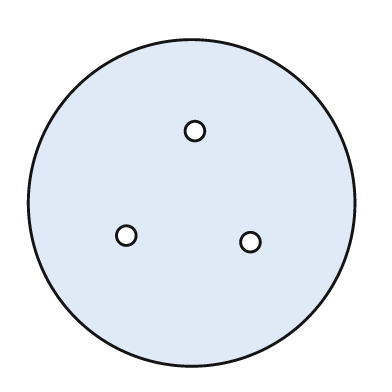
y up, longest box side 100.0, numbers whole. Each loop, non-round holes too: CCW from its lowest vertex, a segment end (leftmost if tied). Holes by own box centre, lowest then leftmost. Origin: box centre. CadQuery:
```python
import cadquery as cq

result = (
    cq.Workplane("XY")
    .moveTo(0.0, 0.0)
    .circle(50.0)
    .moveTo(18.0, -12.0)
    .circle(3.0)
    .moveTo(-20.0, -10.0)
    .circle(3.0)
    .moveTo(1.0, 22.0)
    .circle(3.0)
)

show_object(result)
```